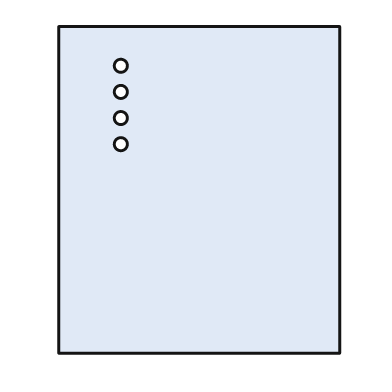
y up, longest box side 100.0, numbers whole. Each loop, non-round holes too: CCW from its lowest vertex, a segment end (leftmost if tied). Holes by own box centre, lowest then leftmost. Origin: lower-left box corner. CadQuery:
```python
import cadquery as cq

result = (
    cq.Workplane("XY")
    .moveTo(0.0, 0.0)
    .lineTo(86.0, 0.0)
    .lineTo(86.0, 100.0)
    .lineTo(0.0, 100.0)
    .close()
    .moveTo(19.0, 64.0)
    .circle(2.0)
    .moveTo(19.0, 72.0)
    .circle(2.0)
    .moveTo(19.0, 80.0)
    .circle(2.0)
    .moveTo(19.0, 88.0)
    .circle(2.0)
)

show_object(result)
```